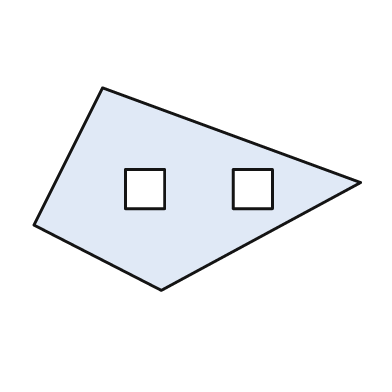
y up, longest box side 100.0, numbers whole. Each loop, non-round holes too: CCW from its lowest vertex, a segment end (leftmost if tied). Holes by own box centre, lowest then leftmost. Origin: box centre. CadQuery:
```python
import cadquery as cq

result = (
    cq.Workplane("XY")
    .moveTo(-11.0, -31.0)
    .lineTo(50.0, 2.0)
    .lineTo(-29.0, 31.0)
    .lineTo(-50.0, -11.0)
    .close()
    .moveTo(-22.0, -6.0)
    .lineTo(-10.0, -6.0)
    .lineTo(-10.0, 6.0)
    .lineTo(-22.0, 6.0)
    .close()
    .moveTo(11.0, -6.0)
    .lineTo(23.0, -6.0)
    .lineTo(23.0, 6.0)
    .lineTo(11.0, 6.0)
    .close()
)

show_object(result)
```